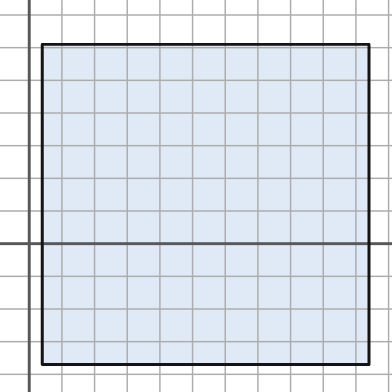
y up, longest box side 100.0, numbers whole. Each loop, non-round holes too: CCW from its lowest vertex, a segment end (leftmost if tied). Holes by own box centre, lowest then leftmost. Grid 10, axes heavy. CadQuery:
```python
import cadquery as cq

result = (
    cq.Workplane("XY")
    .moveTo(4.0, -37.0)
    .lineTo(104.0, -37.0)
    .lineTo(104.0, 61.0)
    .lineTo(4.0, 61.0)
    .close()
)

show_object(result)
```